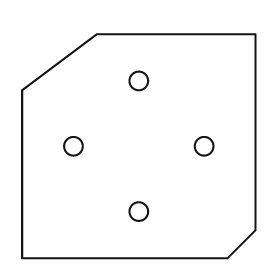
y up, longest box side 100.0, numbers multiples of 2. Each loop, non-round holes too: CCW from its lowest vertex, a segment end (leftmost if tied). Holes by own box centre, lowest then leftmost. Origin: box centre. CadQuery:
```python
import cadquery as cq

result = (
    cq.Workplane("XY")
    .moveTo(-50.0, -48.0)
    .lineTo(38.0, -48.0)
    .lineTo(50.0, -36.0)
    .lineTo(50.0, 48.0)
    .lineTo(-18.0, 48.0)
    .lineTo(-50.0, 24.0)
    .close()
    .moveTo(0.0, -28.0)
    .circle(4.0)
    .moveTo(-28.0, 0.0)
    .circle(4.0)
    .moveTo(28.0, 0.0)
    .circle(4.0)
    .moveTo(0.0, 28.0)
    .circle(4.0)
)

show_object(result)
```